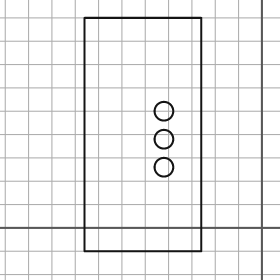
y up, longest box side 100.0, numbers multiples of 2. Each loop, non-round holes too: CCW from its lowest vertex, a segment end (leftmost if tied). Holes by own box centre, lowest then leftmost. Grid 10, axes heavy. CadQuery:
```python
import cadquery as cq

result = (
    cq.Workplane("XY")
    .moveTo(-76.0, -10.0)
    .lineTo(-26.0, -10.0)
    .lineTo(-26.0, 90.0)
    .lineTo(-76.0, 90.0)
    .close()
    .moveTo(-42.0, 26.0)
    .circle(4.0)
    .moveTo(-42.0, 38.0)
    .circle(4.0)
    .moveTo(-42.0, 50.0)
    .circle(4.0)
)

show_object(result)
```